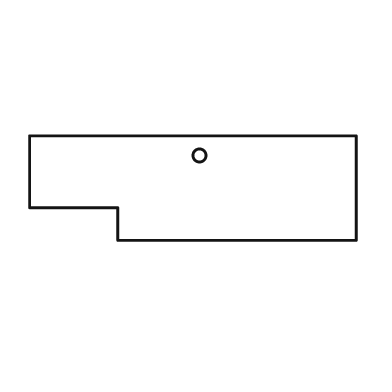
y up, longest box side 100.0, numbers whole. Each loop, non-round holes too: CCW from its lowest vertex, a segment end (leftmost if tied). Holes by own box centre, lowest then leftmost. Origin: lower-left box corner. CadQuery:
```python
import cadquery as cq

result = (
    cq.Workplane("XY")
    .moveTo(27.0, 0.0)
    .lineTo(100.0, 0.0)
    .lineTo(100.0, 32.0)
    .lineTo(0.0, 32.0)
    .lineTo(0.0, 10.0)
    .lineTo(27.0, 10.0)
    .close()
    .moveTo(52.0, 26.0)
    .circle(2.0)
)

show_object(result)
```